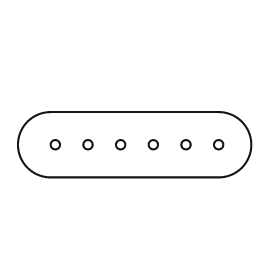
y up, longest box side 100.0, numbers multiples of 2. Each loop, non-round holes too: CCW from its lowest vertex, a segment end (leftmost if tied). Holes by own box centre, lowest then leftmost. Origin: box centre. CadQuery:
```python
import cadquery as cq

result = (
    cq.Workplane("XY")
    .moveTo(-36.0, -14.0)
    .lineTo(36.0, -14.0)
    .threePointArc((50.0, 0.0), (36.0, 14.0))
    .lineTo(-36.0, 14.0)
    .threePointArc((-50.0, 0.0), (-36.0, -14.0))
    .close()
    .moveTo(-34.0, 0.0)
    .circle(2.0)
    .moveTo(-20.0, 0.0)
    .circle(2.0)
    .moveTo(-6.0, 0.0)
    .circle(2.0)
    .moveTo(8.0, 0.0)
    .circle(2.0)
    .moveTo(22.0, 0.0)
    .circle(2.0)
    .moveTo(36.0, 0.0)
    .circle(2.0)
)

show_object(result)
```